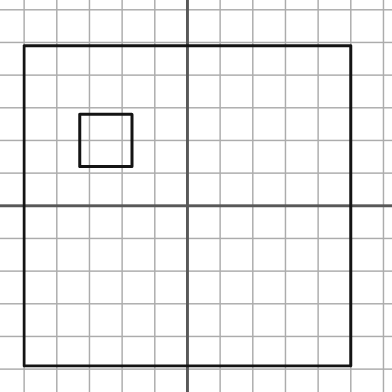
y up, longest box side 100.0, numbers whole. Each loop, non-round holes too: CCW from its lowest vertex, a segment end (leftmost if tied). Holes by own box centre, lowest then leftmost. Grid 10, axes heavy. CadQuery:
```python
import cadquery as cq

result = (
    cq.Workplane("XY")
    .moveTo(-50.0, -49.0)
    .lineTo(50.0, -49.0)
    .lineTo(50.0, 49.0)
    .lineTo(-50.0, 49.0)
    .close()
    .moveTo(-33.0, 12.0)
    .lineTo(-17.0, 12.0)
    .lineTo(-17.0, 28.0)
    .lineTo(-33.0, 28.0)
    .close()
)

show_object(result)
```